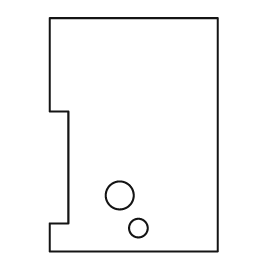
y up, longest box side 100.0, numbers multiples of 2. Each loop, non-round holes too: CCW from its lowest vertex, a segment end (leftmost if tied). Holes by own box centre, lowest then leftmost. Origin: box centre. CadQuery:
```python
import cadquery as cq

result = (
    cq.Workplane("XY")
    .moveTo(-36.0, -50.0)
    .lineTo(36.0, -50.0)
    .lineTo(36.0, 50.0)
    .lineTo(-36.0, 50.0)
    .lineTo(-36.0, 10.0)
    .lineTo(-28.0, 10.0)
    .lineTo(-28.0, -38.0)
    .lineTo(-36.0, -38.0)
    .close()
    .moveTo(2.0, -40.0)
    .circle(4.0)
    .moveTo(-6.0, -26.0)
    .circle(6.0)
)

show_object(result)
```